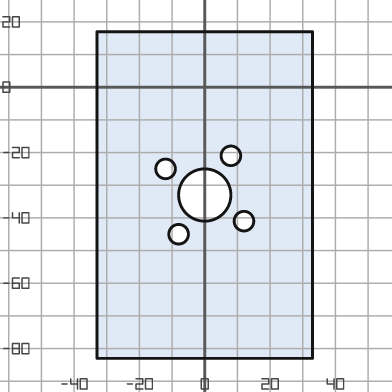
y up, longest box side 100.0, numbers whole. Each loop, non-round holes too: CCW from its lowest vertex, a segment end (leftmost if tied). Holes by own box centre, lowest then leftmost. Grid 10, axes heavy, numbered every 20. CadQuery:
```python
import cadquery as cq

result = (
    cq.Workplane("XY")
    .moveTo(-33.0, -83.0)
    .lineTo(33.0, -83.0)
    .lineTo(33.0, 17.0)
    .lineTo(-33.0, 17.0)
    .close()
    .moveTo(-8.0, -45.0)
    .circle(3.0)
    .moveTo(12.0, -41.0)
    .circle(3.0)
    .moveTo(0.0, -33.0)
    .circle(8.0)
    .moveTo(-12.0, -25.0)
    .circle(3.0)
    .moveTo(8.0, -21.0)
    .circle(3.0)
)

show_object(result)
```